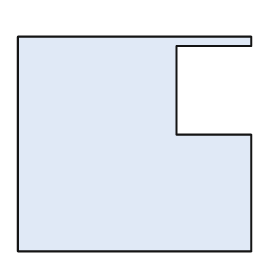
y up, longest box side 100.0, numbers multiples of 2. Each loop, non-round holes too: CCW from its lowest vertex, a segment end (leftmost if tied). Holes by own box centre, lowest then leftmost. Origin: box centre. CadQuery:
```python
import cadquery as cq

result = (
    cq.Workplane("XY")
    .moveTo(-50.0, -46.0)
    .lineTo(50.0, -46.0)
    .lineTo(50.0, 4.0)
    .lineTo(18.0, 4.0)
    .lineTo(18.0, 42.0)
    .lineTo(50.0, 42.0)
    .lineTo(50.0, 46.0)
    .lineTo(-50.0, 46.0)
    .close()
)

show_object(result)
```